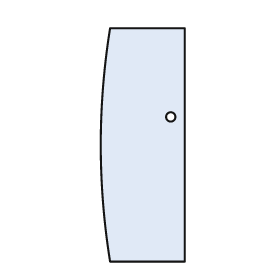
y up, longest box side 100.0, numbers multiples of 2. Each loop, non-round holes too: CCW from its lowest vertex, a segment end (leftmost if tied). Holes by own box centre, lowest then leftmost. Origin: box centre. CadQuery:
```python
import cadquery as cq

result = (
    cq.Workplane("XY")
    .moveTo(-14.0, -50.0)
    .lineTo(18.0, -50.0)
    .lineTo(18.0, 50.0)
    .lineTo(-14.0, 50.0)
    .threePointArc((-18.0, 0.0), (-14.0, -50.0))
    .close()
    .moveTo(12.0, 12.0)
    .circle(2.0)
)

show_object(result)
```